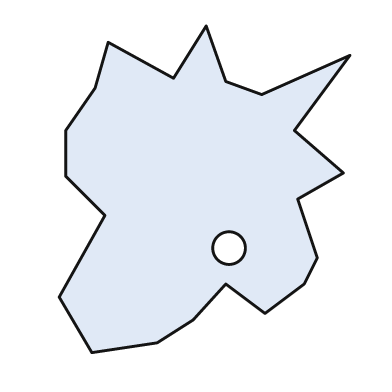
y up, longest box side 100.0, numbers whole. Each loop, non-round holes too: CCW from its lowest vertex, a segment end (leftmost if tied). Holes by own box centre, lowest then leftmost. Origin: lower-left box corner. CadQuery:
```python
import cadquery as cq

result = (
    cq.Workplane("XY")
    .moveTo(10.0, 0.0)
    .lineTo(30.0, 3.0)
    .lineTo(41.0, 10.0)
    .lineTo(51.0, 21.0)
    .lineTo(63.0, 12.0)
    .lineTo(75.0, 21.0)
    .lineTo(79.0, 29.0)
    .lineTo(73.0, 47.0)
    .lineTo(87.0, 55.0)
    .lineTo(72.0, 68.0)
    .lineTo(89.0, 91.0)
    .lineTo(62.0, 79.0)
    .lineTo(51.0, 83.0)
    .lineTo(45.0, 100.0)
    .lineTo(35.0, 84.0)
    .lineTo(15.0, 95.0)
    .lineTo(11.0, 81.0)
    .lineTo(2.0, 68.0)
    .lineTo(2.0, 54.0)
    .lineTo(14.0, 42.0)
    .lineTo(0.0, 17.0)
    .close()
    .moveTo(52.0, 32.0)
    .circle(5.0)
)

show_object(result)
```